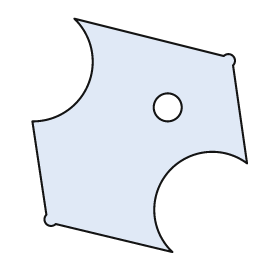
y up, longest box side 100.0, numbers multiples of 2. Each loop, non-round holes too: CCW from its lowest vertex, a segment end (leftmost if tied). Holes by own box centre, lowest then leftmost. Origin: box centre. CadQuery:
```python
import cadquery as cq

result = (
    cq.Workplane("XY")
    .moveTo(14.0, -50.0)
    .threePointArc((12.0, -16.0), (46.0, -12.0))
    .lineTo(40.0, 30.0)
    .threePointArc((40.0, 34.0), (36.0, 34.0))
    .lineTo(-28.0, 50.0)
    .threePointArc((-22.0, 22.0), (-46.0, 6.0))
    .lineTo(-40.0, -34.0)
    .threePointArc((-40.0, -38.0), (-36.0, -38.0))
    .close()
    .moveTo(12.0, 12.0)
    .circle(6.0)
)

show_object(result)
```